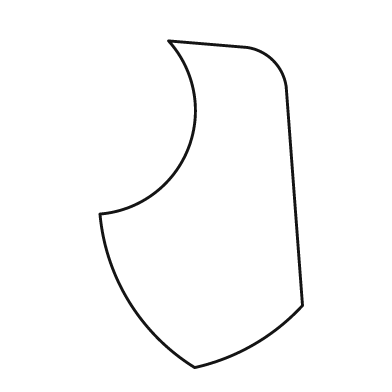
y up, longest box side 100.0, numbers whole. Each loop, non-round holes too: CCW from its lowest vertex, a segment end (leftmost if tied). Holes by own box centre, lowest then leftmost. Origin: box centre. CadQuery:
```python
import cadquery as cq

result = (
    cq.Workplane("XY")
    .moveTo(-2.0, -50.0)
    .threePointArc((16.0, -43.0), (31.0, -31.0))
    .lineTo(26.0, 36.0)
    .threePointArc((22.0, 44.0), (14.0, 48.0))
    .lineTo(-10.0, 50.0)
    .threePointArc((-4.0, 17.0), (-31.0, -3.0))
    .threePointArc((-22.0, -30.0), (-2.0, -50.0))
    .close()
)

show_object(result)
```